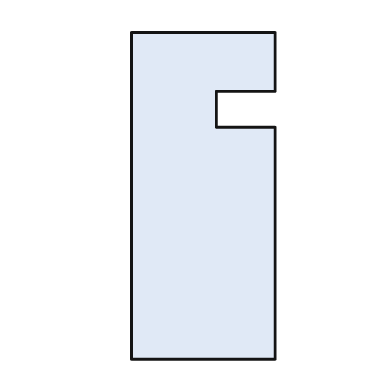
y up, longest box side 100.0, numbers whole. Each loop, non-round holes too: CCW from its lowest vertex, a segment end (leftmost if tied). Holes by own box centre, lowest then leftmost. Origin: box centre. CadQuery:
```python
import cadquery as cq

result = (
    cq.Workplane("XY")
    .moveTo(-22.0, -50.0)
    .lineTo(22.0, -50.0)
    .lineTo(22.0, 21.0)
    .lineTo(4.0, 21.0)
    .lineTo(4.0, 32.0)
    .lineTo(22.0, 32.0)
    .lineTo(22.0, 50.0)
    .lineTo(-22.0, 50.0)
    .close()
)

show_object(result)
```